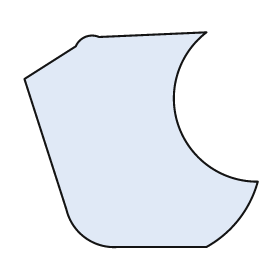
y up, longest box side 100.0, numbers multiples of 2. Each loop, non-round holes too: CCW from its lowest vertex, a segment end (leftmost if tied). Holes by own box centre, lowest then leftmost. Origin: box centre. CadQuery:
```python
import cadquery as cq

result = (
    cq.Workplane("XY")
    .moveTo(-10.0, -46.0)
    .lineTo(28.0, -46.0)
    .threePointArc((42.0, -34.0), (50.0, -18.0))
    .threePointArc((16.0, 6.0), (28.0, 46.0))
    .lineTo(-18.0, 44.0)
    .threePointArc((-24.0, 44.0), (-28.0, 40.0))
    .lineTo(-50.0, 26.0)
    .lineTo(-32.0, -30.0)
    .threePointArc((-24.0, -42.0), (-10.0, -46.0))
    .close()
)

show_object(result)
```